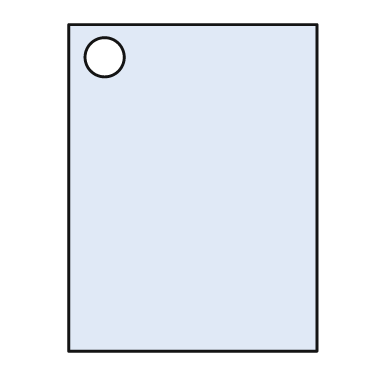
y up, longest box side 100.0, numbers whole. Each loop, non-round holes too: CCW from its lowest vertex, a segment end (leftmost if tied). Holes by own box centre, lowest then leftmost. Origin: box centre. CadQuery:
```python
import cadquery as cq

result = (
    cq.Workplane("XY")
    .moveTo(-38.0, -50.0)
    .lineTo(38.0, -50.0)
    .lineTo(38.0, 50.0)
    .lineTo(-38.0, 50.0)
    .close()
    .moveTo(-27.0, 40.0)
    .circle(6.0)
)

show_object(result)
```